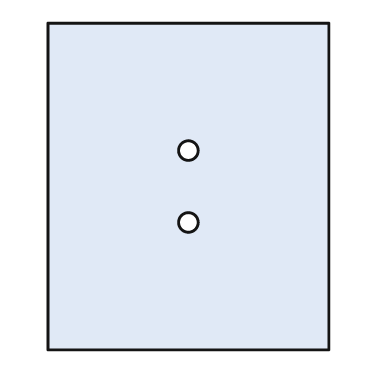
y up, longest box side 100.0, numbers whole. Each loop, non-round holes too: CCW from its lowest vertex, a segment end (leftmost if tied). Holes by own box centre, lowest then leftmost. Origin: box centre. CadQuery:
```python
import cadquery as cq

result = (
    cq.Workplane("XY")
    .moveTo(-43.0, -50.0)
    .lineTo(43.0, -50.0)
    .lineTo(43.0, 50.0)
    .lineTo(-43.0, 50.0)
    .close()
    .moveTo(0.0, -11.0)
    .circle(3.0)
    .moveTo(0.0, 11.0)
    .circle(3.0)
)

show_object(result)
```